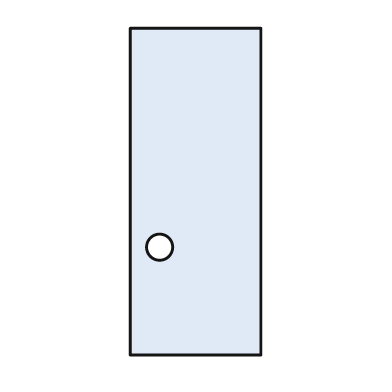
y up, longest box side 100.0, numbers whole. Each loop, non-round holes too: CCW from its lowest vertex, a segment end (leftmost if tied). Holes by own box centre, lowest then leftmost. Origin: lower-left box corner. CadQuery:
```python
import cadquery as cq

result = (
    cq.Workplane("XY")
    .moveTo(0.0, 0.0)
    .lineTo(40.0, 0.0)
    .lineTo(40.0, 100.0)
    .lineTo(0.0, 100.0)
    .close()
    .moveTo(9.0, 33.0)
    .circle(4.0)
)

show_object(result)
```